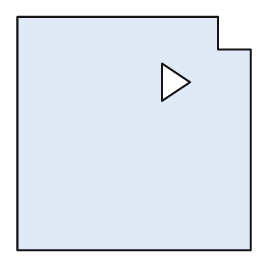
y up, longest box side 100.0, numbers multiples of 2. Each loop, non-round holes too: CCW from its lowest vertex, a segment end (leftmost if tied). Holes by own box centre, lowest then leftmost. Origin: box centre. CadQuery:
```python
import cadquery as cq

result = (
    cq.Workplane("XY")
    .moveTo(-50.0, -50.0)
    .lineTo(50.0, -50.0)
    .lineTo(50.0, 36.0)
    .lineTo(36.0, 36.0)
    .lineTo(36.0, 50.0)
    .lineTo(-50.0, 50.0)
    .close()
    .moveTo(12.0, 14.0)
    .lineTo(24.0, 22.0)
    .lineTo(12.0, 30.0)
    .close()
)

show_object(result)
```